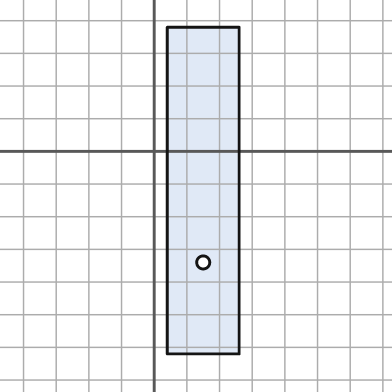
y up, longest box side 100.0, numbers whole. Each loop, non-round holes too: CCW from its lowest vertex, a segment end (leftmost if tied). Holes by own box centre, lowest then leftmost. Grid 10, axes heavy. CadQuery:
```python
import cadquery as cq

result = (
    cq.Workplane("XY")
    .moveTo(4.0, -62.0)
    .lineTo(26.0, -62.0)
    .lineTo(26.0, 38.0)
    .lineTo(4.0, 38.0)
    .close()
    .moveTo(15.0, -34.0)
    .circle(2.0)
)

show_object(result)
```